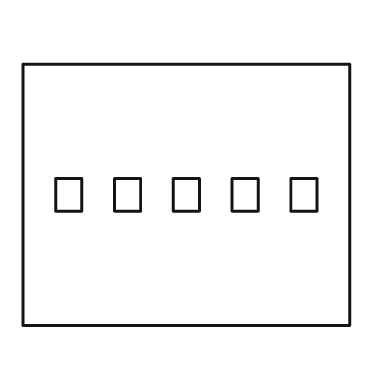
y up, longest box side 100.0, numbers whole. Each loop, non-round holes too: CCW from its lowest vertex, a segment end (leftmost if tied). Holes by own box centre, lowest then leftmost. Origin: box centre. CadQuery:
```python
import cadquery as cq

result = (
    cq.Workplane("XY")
    .moveTo(-50.0, -40.0)
    .lineTo(50.0, -40.0)
    .lineTo(50.0, 40.0)
    .lineTo(-50.0, 40.0)
    .close()
    .moveTo(-40.0, -5.0)
    .lineTo(-32.0, -5.0)
    .lineTo(-32.0, 5.0)
    .lineTo(-40.0, 5.0)
    .close()
    .moveTo(-22.0, -5.0)
    .lineTo(-14.0, -5.0)
    .lineTo(-14.0, 5.0)
    .lineTo(-22.0, 5.0)
    .close()
    .moveTo(-4.0, -5.0)
    .lineTo(4.0, -5.0)
    .lineTo(4.0, 5.0)
    .lineTo(-4.0, 5.0)
    .close()
    .moveTo(14.0, -5.0)
    .lineTo(22.0, -5.0)
    .lineTo(22.0, 5.0)
    .lineTo(14.0, 5.0)
    .close()
    .moveTo(32.0, -5.0)
    .lineTo(40.0, -5.0)
    .lineTo(40.0, 5.0)
    .lineTo(32.0, 5.0)
    .close()
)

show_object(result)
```